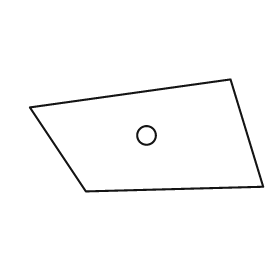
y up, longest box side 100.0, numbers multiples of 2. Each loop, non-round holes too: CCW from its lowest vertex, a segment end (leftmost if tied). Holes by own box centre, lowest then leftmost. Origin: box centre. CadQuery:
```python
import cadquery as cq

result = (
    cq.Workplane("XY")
    .moveTo(-26.0, -24.0)
    .lineTo(50.0, -22.0)
    .lineTo(36.0, 24.0)
    .lineTo(-50.0, 12.0)
    .close()
    .moveTo(0.0, 0.0)
    .circle(4.0)
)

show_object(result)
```